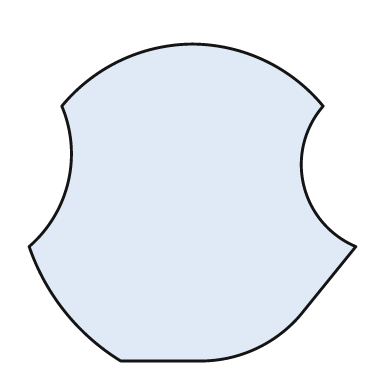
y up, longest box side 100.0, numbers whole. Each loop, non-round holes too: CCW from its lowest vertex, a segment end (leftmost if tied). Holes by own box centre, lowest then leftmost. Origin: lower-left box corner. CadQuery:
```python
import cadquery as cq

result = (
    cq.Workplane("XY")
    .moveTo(28.0, 0.0)
    .lineTo(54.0, 0.0)
    .threePointArc((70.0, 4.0), (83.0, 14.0))
    .lineTo(100.0, 35.0)
    .threePointArc((84.0, 54.0), (90.0, 78.0))
    .threePointArc((72.0, 92.0), (50.0, 97.0))
    .threePointArc((28.0, 92.0), (10.0, 78.0))
    .threePointArc((12.0, 55.0), (0.0, 35.0))
    .threePointArc((11.0, 15.0), (28.0, 0.0))
    .close()
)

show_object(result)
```